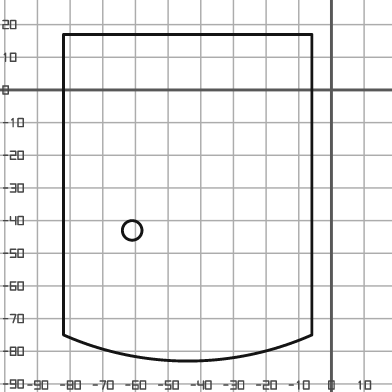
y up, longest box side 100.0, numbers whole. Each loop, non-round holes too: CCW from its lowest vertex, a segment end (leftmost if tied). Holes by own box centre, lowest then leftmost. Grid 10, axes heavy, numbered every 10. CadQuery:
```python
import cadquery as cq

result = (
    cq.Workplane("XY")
    .moveTo(-82.0, -75.0)
    .threePointArc((-44.0, -83.0), (-6.0, -75.0))
    .lineTo(-6.0, 17.0)
    .lineTo(-82.0, 17.0)
    .close()
    .moveTo(-61.0, -43.0)
    .circle(3.0)
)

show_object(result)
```